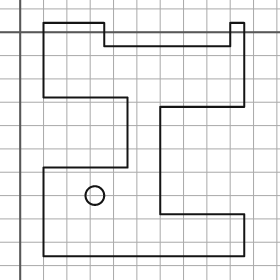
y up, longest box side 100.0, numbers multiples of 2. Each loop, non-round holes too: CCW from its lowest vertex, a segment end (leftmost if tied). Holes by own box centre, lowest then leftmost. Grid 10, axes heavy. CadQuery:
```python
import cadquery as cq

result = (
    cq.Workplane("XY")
    .moveTo(10.0, -96.0)
    .lineTo(96.0, -96.0)
    .lineTo(96.0, -78.0)
    .lineTo(60.0, -78.0)
    .lineTo(60.0, -32.0)
    .lineTo(96.0, -32.0)
    .lineTo(96.0, 4.0)
    .lineTo(90.0, 4.0)
    .lineTo(90.0, -6.0)
    .lineTo(36.0, -6.0)
    .lineTo(36.0, 4.0)
    .lineTo(10.0, 4.0)
    .lineTo(10.0, -28.0)
    .lineTo(46.0, -28.0)
    .lineTo(46.0, -58.0)
    .lineTo(10.0, -58.0)
    .close()
    .moveTo(32.0, -70.0)
    .circle(4.0)
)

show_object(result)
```